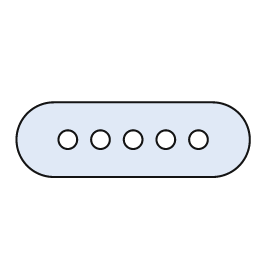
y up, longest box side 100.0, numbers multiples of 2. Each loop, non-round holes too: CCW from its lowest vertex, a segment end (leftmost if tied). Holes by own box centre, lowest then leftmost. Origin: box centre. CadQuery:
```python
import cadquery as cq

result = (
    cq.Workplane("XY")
    .moveTo(-34.0, -16.0)
    .lineTo(34.0, -16.0)
    .threePointArc((50.0, 0.0), (34.0, 16.0))
    .lineTo(-34.0, 16.0)
    .threePointArc((-50.0, 0.0), (-34.0, -16.0))
    .close()
    .moveTo(-28.0, 0.0)
    .circle(4.0)
    .moveTo(-14.0, 0.0)
    .circle(4.0)
    .moveTo(0.0, 0.0)
    .circle(4.0)
    .moveTo(14.0, 0.0)
    .circle(4.0)
    .moveTo(28.0, 0.0)
    .circle(4.0)
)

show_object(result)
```